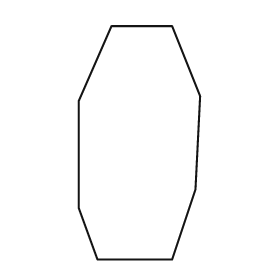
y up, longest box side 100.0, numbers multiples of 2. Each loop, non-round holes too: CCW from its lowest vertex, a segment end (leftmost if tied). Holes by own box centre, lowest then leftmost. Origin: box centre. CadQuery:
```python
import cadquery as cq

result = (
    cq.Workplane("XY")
    .moveTo(-18.0, -50.0)
    .lineTo(14.0, -50.0)
    .lineTo(24.0, -20.0)
    .lineTo(26.0, 20.0)
    .lineTo(14.0, 50.0)
    .lineTo(-12.0, 50.0)
    .lineTo(-26.0, 18.0)
    .lineTo(-26.0, -28.0)
    .close()
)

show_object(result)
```